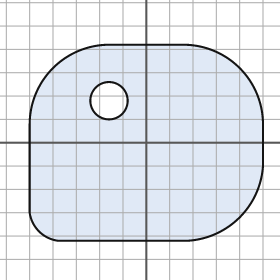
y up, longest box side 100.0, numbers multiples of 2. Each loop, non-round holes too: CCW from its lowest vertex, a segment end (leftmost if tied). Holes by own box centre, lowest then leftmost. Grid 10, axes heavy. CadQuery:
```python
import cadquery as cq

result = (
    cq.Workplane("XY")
    .moveTo(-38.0, -42.0)
    .lineTo(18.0, -42.0)
    .threePointArc((40.0, -32.0), (50.0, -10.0))
    .lineTo(50.0, 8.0)
    .threePointArc((40.0, 32.0), (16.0, 42.0))
    .lineTo(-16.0, 42.0)
    .threePointArc((-40.0, 32.0), (-50.0, 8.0))
    .lineTo(-50.0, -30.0)
    .threePointArc((-46.0, -38.0), (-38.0, -42.0))
    .close()
    .moveTo(-16.0, 18.0)
    .circle(8.0)
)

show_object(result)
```